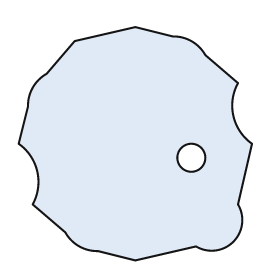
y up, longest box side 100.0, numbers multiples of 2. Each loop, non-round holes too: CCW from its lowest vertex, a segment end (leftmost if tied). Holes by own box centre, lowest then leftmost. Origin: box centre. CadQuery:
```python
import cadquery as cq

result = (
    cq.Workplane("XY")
    .moveTo(0.0, -50.0)
    .lineTo(26.0, -44.0)
    .threePointArc((42.0, -42.0), (44.0, -26.0))
    .lineTo(50.0, 0.0)
    .threePointArc((42.0, 12.0), (44.0, 26.0))
    .lineTo(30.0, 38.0)
    .threePointArc((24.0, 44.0), (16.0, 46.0))
    .lineTo(0.0, 50.0)
    .lineTo(-26.0, 44.0)
    .lineTo(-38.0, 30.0)
    .threePointArc((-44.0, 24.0), (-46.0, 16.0))
    .lineTo(-50.0, 0.0)
    .threePointArc((-42.0, -12.0), (-44.0, -26.0))
    .lineTo(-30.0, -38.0)
    .threePointArc((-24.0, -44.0), (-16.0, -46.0))
    .close()
    .moveTo(24.0, -6.0)
    .circle(6.0)
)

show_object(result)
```